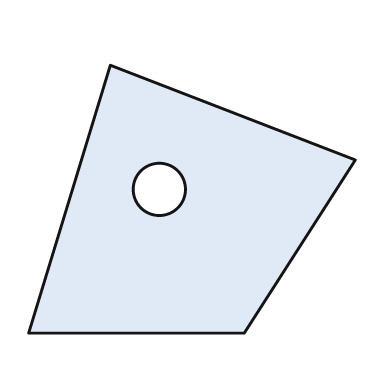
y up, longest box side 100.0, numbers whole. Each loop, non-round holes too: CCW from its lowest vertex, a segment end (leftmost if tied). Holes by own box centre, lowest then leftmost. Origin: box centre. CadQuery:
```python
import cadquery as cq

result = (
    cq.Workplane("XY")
    .moveTo(-50.0, -41.0)
    .lineTo(16.0, -41.0)
    .lineTo(50.0, 12.0)
    .lineTo(-25.0, 41.0)
    .close()
    .moveTo(-10.0, 3.0)
    .circle(8.0)
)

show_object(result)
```